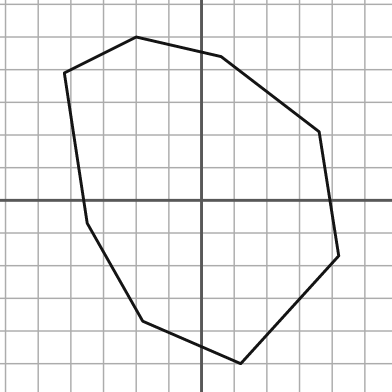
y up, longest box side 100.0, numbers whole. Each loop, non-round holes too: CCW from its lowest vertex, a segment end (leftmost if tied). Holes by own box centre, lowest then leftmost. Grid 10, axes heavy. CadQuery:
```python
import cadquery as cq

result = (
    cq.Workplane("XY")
    .moveTo(12.0, -50.0)
    .lineTo(42.0, -17.0)
    .lineTo(36.0, 21.0)
    .lineTo(6.0, 44.0)
    .lineTo(-20.0, 50.0)
    .lineTo(-42.0, 39.0)
    .lineTo(-35.0, -7.0)
    .lineTo(-18.0, -37.0)
    .close()
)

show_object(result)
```